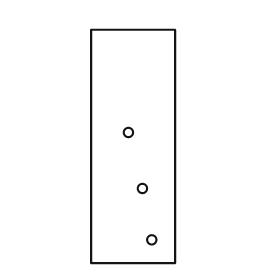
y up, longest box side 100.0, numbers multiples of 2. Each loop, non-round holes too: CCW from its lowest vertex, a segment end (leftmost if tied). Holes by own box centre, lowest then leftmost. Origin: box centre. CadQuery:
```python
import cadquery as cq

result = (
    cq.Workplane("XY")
    .moveTo(-18.0, -50.0)
    .lineTo(18.0, -50.0)
    .lineTo(18.0, 50.0)
    .lineTo(-18.0, 50.0)
    .close()
    .moveTo(8.0, -40.0)
    .circle(2.0)
    .moveTo(4.0, -18.0)
    .circle(2.0)
    .moveTo(-2.0, 6.0)
    .circle(2.0)
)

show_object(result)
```